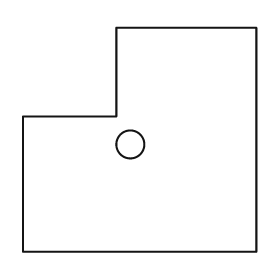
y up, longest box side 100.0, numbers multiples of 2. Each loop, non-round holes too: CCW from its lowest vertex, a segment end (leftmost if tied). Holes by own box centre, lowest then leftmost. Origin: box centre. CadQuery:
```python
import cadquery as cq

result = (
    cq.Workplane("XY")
    .moveTo(-50.0, -48.0)
    .lineTo(50.0, -48.0)
    .lineTo(50.0, 48.0)
    .lineTo(-10.0, 48.0)
    .lineTo(-10.0, 10.0)
    .lineTo(-50.0, 10.0)
    .close()
    .moveTo(-4.0, -2.0)
    .circle(6.0)
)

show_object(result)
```